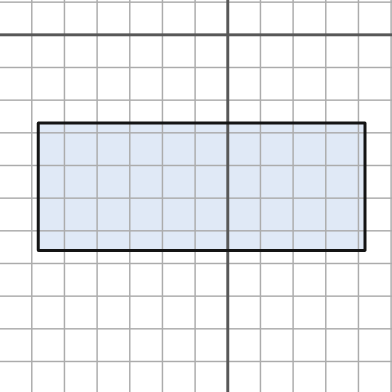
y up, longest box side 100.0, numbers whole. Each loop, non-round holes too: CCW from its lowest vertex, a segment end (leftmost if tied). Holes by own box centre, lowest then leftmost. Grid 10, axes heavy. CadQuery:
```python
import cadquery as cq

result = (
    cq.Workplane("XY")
    .moveTo(-58.0, -66.0)
    .lineTo(42.0, -66.0)
    .lineTo(42.0, -27.0)
    .lineTo(-58.0, -27.0)
    .close()
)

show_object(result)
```